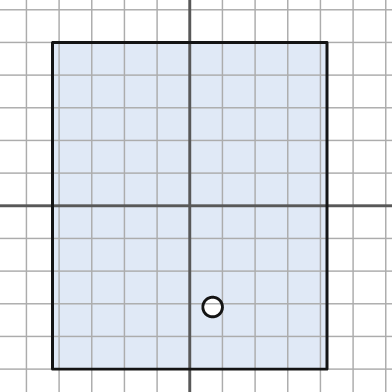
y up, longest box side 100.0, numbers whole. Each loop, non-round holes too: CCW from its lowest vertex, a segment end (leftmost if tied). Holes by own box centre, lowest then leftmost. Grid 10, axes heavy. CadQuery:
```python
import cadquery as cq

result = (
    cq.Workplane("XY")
    .moveTo(-42.0, -50.0)
    .lineTo(42.0, -50.0)
    .lineTo(42.0, 50.0)
    .lineTo(-42.0, 50.0)
    .close()
    .moveTo(7.0, -31.0)
    .circle(3.0)
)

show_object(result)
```